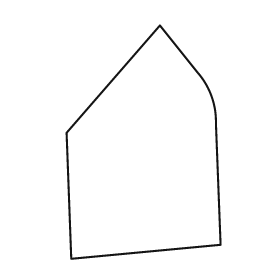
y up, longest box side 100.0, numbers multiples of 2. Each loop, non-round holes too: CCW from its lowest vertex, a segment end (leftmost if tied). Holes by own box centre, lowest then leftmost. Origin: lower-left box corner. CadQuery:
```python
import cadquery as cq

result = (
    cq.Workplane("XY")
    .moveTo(2.0, 0.0)
    .lineTo(66.0, 6.0)
    .lineTo(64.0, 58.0)
    .threePointArc((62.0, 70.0), (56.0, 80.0))
    .lineTo(40.0, 100.0)
    .lineTo(0.0, 54.0)
    .close()
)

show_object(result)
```